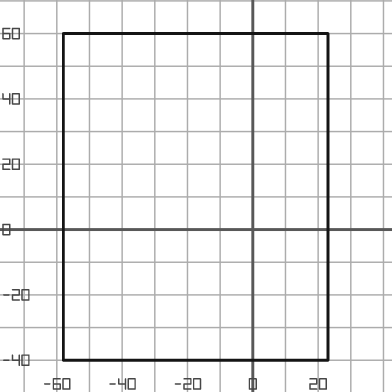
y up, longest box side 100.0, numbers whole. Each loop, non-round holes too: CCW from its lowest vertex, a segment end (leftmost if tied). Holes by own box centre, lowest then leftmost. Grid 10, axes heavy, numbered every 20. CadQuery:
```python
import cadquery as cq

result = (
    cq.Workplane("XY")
    .moveTo(-58.0, -40.0)
    .lineTo(23.0, -40.0)
    .lineTo(23.0, 60.0)
    .lineTo(-58.0, 60.0)
    .close()
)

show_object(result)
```